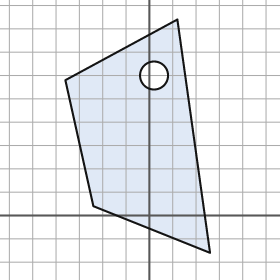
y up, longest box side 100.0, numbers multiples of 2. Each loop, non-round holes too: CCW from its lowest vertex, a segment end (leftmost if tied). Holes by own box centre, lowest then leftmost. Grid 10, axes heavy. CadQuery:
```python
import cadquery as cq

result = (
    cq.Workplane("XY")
    .moveTo(26.0, -16.0)
    .lineTo(12.0, 84.0)
    .lineTo(-36.0, 58.0)
    .lineTo(-24.0, 4.0)
    .close()
    .moveTo(2.0, 60.0)
    .circle(6.0)
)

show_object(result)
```